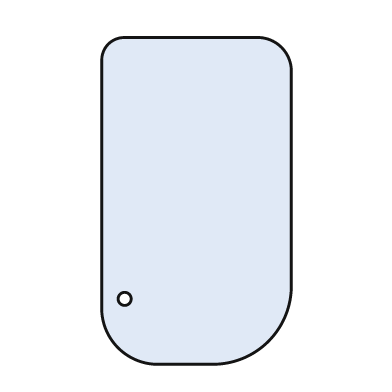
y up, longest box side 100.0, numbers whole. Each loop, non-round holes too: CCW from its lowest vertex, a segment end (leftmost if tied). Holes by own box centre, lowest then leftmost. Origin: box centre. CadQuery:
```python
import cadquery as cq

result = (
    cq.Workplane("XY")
    .moveTo(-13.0, -50.0)
    .lineTo(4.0, -50.0)
    .threePointArc((22.0, -43.0), (29.0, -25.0))
    .lineTo(29.0, 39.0)
    .threePointArc((26.0, 47.0), (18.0, 50.0))
    .lineTo(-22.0, 50.0)
    .threePointArc((-27.0, 48.0), (-29.0, 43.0))
    .lineTo(-29.0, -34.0)
    .threePointArc((-24.0, -45.0), (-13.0, -50.0))
    .close()
    .moveTo(-22.0, -30.0)
    .circle(2.0)
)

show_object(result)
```